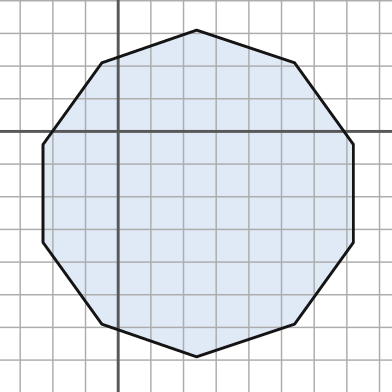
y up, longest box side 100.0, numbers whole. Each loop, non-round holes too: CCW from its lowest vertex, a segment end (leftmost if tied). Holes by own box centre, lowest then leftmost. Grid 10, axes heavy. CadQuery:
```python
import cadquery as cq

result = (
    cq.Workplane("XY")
    .moveTo(24.0, -69.0)
    .lineTo(54.0, -59.0)
    .lineTo(72.0, -34.0)
    .lineTo(72.0, -4.0)
    .lineTo(54.0, 21.0)
    .lineTo(24.0, 31.0)
    .lineTo(-5.0, 21.0)
    .lineTo(-23.0, -4.0)
    .lineTo(-23.0, -34.0)
    .lineTo(-5.0, -59.0)
    .close()
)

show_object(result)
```